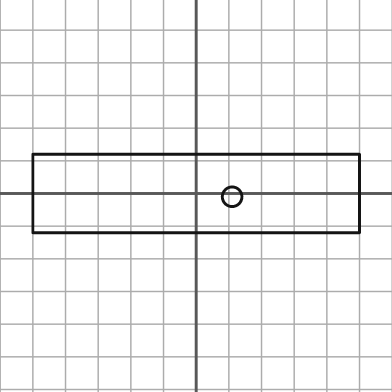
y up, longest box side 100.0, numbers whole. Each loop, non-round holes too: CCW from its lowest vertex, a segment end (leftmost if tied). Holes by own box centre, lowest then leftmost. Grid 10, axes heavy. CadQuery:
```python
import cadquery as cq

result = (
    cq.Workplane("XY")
    .moveTo(-50.0, -12.0)
    .lineTo(50.0, -12.0)
    .lineTo(50.0, 12.0)
    .lineTo(-50.0, 12.0)
    .close()
    .moveTo(11.0, -1.0)
    .circle(3.0)
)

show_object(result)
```